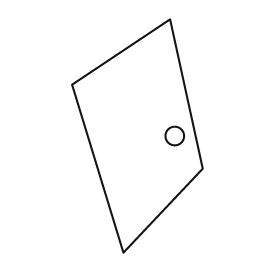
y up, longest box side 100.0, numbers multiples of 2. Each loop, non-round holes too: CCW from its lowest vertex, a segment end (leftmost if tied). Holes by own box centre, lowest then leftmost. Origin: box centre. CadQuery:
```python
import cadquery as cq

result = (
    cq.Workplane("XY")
    .moveTo(-6.0, -50.0)
    .lineTo(28.0, -14.0)
    .lineTo(14.0, 50.0)
    .lineTo(-28.0, 22.0)
    .close()
    .moveTo(16.0, 0.0)
    .circle(4.0)
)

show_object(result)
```